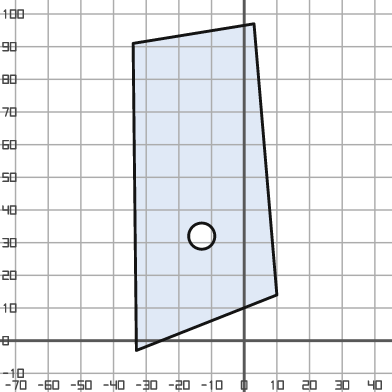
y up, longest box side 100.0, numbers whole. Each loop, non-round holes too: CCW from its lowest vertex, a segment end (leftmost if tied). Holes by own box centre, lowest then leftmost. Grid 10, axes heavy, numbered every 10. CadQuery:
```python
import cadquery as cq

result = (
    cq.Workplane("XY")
    .moveTo(-33.0, -3.0)
    .lineTo(10.0, 14.0)
    .lineTo(3.0, 97.0)
    .lineTo(-34.0, 91.0)
    .close()
    .moveTo(-13.0, 32.0)
    .circle(4.0)
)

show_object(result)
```